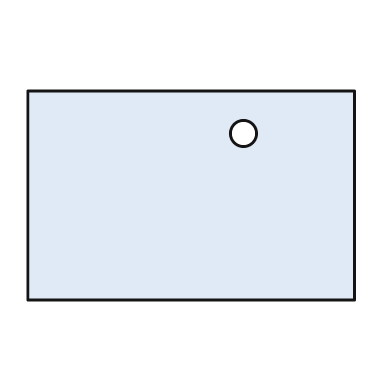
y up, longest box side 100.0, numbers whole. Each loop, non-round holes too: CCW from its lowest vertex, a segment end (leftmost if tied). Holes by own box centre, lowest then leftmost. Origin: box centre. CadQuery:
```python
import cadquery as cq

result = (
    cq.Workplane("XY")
    .moveTo(-50.0, -32.0)
    .lineTo(50.0, -32.0)
    .lineTo(50.0, 32.0)
    .lineTo(-50.0, 32.0)
    .close()
    .moveTo(16.0, 19.0)
    .circle(4.0)
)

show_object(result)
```